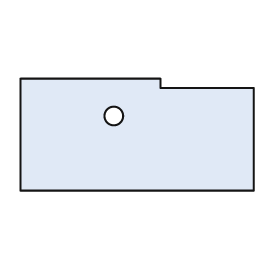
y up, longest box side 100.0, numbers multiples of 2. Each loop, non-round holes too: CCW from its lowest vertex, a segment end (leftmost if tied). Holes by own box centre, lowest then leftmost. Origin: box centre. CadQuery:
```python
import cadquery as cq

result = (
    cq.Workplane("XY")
    .moveTo(-50.0, -24.0)
    .lineTo(50.0, -24.0)
    .lineTo(50.0, 20.0)
    .lineTo(10.0, 20.0)
    .lineTo(10.0, 24.0)
    .lineTo(-50.0, 24.0)
    .close()
    .moveTo(-10.0, 8.0)
    .circle(4.0)
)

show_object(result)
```